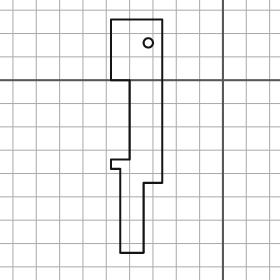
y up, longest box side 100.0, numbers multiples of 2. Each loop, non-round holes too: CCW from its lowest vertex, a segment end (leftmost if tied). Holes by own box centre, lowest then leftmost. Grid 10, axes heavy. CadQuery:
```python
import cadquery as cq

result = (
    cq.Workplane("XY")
    .moveTo(-44.0, -74.0)
    .lineTo(-34.0, -74.0)
    .lineTo(-34.0, -44.0)
    .lineTo(-26.0, -44.0)
    .lineTo(-26.0, 26.0)
    .lineTo(-48.0, 26.0)
    .lineTo(-48.0, 0.0)
    .lineTo(-40.0, 0.0)
    .lineTo(-40.0, -34.0)
    .lineTo(-48.0, -34.0)
    .lineTo(-48.0, -38.0)
    .lineTo(-44.0, -38.0)
    .close()
    .moveTo(-32.0, 16.0)
    .circle(2.0)
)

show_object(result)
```